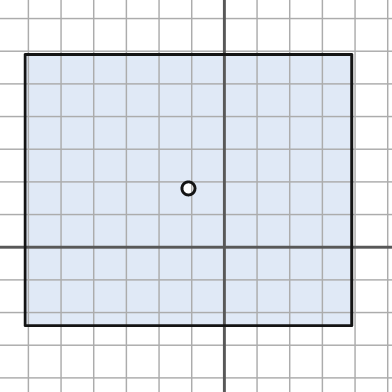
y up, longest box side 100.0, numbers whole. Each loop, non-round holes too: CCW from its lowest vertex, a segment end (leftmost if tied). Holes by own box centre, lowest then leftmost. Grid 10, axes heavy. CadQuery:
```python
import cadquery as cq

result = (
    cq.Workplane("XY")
    .moveTo(-61.0, -24.0)
    .lineTo(39.0, -24.0)
    .lineTo(39.0, 59.0)
    .lineTo(-61.0, 59.0)
    .close()
    .moveTo(-11.0, 18.0)
    .circle(2.0)
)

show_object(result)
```